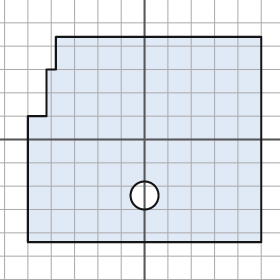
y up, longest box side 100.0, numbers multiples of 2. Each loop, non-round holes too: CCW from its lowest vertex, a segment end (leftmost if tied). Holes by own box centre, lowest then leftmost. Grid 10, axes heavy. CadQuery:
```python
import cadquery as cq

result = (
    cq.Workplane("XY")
    .moveTo(-50.0, -44.0)
    .lineTo(50.0, -44.0)
    .lineTo(50.0, 44.0)
    .lineTo(-38.0, 44.0)
    .lineTo(-38.0, 30.0)
    .lineTo(-42.0, 30.0)
    .lineTo(-42.0, 10.0)
    .lineTo(-50.0, 10.0)
    .close()
    .moveTo(0.0, -24.0)
    .circle(6.0)
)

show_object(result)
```